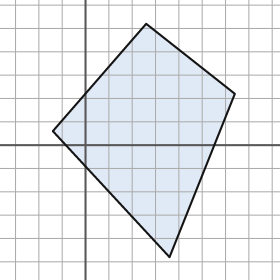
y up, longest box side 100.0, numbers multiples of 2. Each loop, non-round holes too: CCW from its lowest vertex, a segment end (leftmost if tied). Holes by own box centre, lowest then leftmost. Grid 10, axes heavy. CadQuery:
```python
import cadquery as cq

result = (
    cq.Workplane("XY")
    .moveTo(36.0, -48.0)
    .lineTo(64.0, 22.0)
    .lineTo(26.0, 52.0)
    .lineTo(-14.0, 6.0)
    .close()
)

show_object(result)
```